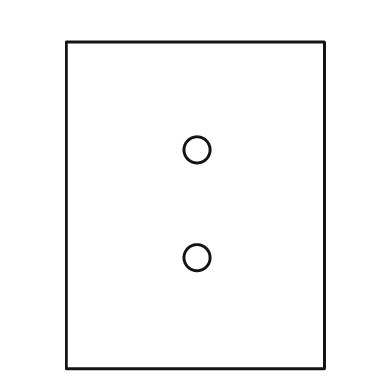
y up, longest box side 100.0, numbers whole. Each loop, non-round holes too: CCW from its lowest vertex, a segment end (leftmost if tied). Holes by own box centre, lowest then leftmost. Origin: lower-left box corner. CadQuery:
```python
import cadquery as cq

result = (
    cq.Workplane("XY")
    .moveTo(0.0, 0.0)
    .lineTo(79.0, 0.0)
    .lineTo(79.0, 100.0)
    .lineTo(0.0, 100.0)
    .close()
    .moveTo(40.0, 34.0)
    .circle(4.0)
    .moveTo(40.0, 67.0)
    .circle(4.0)
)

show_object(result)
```